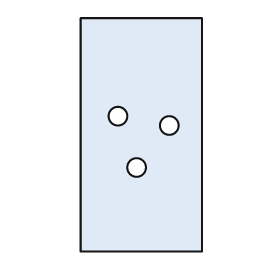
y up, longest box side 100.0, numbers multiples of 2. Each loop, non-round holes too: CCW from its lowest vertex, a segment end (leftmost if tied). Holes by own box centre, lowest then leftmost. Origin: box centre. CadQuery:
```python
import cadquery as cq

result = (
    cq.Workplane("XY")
    .moveTo(-26.0, -50.0)
    .lineTo(26.0, -50.0)
    .lineTo(26.0, 50.0)
    .lineTo(-26.0, 50.0)
    .close()
    .moveTo(-2.0, -14.0)
    .circle(4.0)
    .moveTo(12.0, 4.0)
    .circle(4.0)
    .moveTo(-10.0, 8.0)
    .circle(4.0)
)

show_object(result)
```